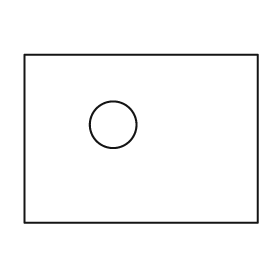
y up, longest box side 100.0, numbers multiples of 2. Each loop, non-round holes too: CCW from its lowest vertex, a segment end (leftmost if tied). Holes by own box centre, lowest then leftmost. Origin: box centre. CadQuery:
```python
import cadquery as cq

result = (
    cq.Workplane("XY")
    .moveTo(-50.0, -36.0)
    .lineTo(50.0, -36.0)
    .lineTo(50.0, 36.0)
    .lineTo(-50.0, 36.0)
    .close()
    .moveTo(-12.0, 6.0)
    .circle(10.0)
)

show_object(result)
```